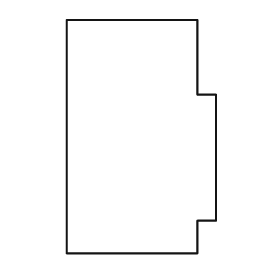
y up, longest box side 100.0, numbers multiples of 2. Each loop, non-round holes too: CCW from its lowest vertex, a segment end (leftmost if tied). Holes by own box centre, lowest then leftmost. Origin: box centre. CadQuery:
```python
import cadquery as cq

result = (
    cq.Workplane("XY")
    .moveTo(-32.0, -50.0)
    .lineTo(24.0, -50.0)
    .lineTo(24.0, -36.0)
    .lineTo(32.0, -36.0)
    .lineTo(32.0, 18.0)
    .lineTo(24.0, 18.0)
    .lineTo(24.0, 50.0)
    .lineTo(-32.0, 50.0)
    .close()
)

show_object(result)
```